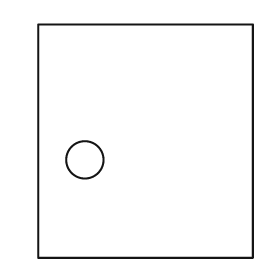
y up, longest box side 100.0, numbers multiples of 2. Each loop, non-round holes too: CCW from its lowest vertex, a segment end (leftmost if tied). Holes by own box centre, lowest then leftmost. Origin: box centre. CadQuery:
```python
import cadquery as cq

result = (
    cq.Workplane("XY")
    .moveTo(-46.0, -50.0)
    .lineTo(46.0, -50.0)
    .lineTo(46.0, 50.0)
    .lineTo(-46.0, 50.0)
    .close()
    .moveTo(-26.0, -8.0)
    .circle(8.0)
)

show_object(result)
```